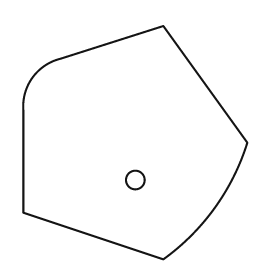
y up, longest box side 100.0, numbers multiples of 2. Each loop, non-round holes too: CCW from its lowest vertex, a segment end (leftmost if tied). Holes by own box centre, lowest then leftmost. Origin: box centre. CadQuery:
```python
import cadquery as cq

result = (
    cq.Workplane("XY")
    .moveTo(12.0, -50.0)
    .threePointArc((34.0, -28.0), (48.0, 0.0))
    .lineTo(12.0, 50.0)
    .lineTo(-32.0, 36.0)
    .threePointArc((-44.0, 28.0), (-48.0, 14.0))
    .lineTo(-48.0, -30.0)
    .close()
    .moveTo(0.0, -16.0)
    .circle(4.0)
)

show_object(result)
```